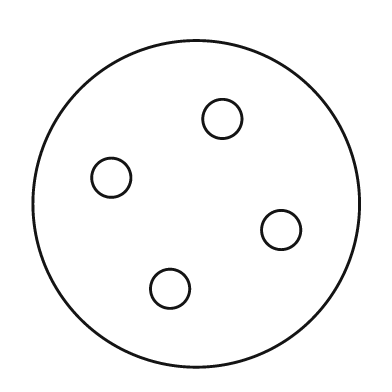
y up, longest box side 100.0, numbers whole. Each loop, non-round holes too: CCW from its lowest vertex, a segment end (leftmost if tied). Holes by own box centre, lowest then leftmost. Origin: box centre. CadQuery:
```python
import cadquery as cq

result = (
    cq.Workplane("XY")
    .moveTo(0.0, 0.0)
    .circle(50.0)
    .moveTo(-8.0, -26.0)
    .circle(6.0)
    .moveTo(26.0, -8.0)
    .circle(6.0)
    .moveTo(-26.0, 8.0)
    .circle(6.0)
    .moveTo(8.0, 26.0)
    .circle(6.0)
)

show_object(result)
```